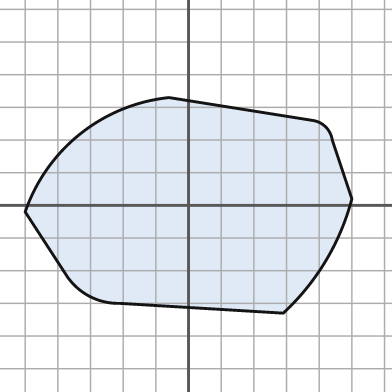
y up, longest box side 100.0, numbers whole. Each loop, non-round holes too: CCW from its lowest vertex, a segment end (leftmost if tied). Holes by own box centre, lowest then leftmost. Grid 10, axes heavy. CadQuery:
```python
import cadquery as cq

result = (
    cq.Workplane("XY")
    .moveTo(29.0, -33.0)
    .threePointArc((42.0, -17.0), (50.0, 2.0))
    .lineTo(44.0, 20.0)
    .threePointArc((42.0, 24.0), (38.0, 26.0))
    .lineTo(-6.0, 33.0)
    .threePointArc((-33.0, 22.0), (-50.0, -2.0))
    .lineTo(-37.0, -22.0)
    .threePointArc((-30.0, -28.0), (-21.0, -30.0))
    .close()
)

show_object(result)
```